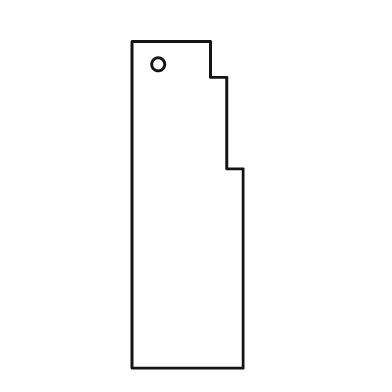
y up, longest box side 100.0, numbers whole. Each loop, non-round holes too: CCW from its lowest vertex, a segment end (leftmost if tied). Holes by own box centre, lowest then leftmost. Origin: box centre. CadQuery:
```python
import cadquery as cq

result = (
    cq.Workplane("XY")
    .moveTo(-17.0, -50.0)
    .lineTo(17.0, -50.0)
    .lineTo(17.0, 11.0)
    .lineTo(12.0, 11.0)
    .lineTo(12.0, 39.0)
    .lineTo(7.0, 39.0)
    .lineTo(7.0, 50.0)
    .lineTo(-17.0, 50.0)
    .close()
    .moveTo(-9.0, 43.0)
    .circle(2.0)
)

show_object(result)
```